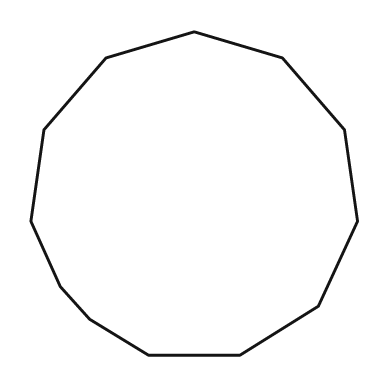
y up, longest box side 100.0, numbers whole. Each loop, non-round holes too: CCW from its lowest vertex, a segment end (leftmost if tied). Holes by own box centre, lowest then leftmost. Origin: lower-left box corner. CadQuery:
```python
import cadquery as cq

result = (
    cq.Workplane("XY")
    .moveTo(36.0, 0.0)
    .lineTo(64.0, 0.0)
    .lineTo(88.0, 15.0)
    .lineTo(100.0, 41.0)
    .lineTo(96.0, 69.0)
    .lineTo(77.0, 91.0)
    .lineTo(50.0, 99.0)
    .lineTo(23.0, 91.0)
    .lineTo(4.0, 69.0)
    .lineTo(0.0, 41.0)
    .lineTo(9.0, 21.0)
    .lineTo(18.0, 11.0)
    .close()
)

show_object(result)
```